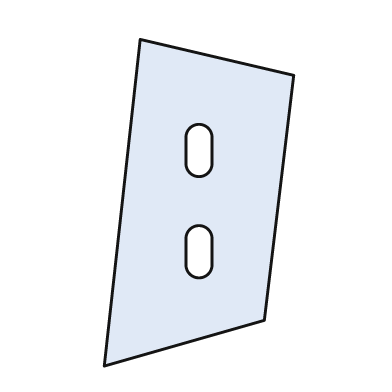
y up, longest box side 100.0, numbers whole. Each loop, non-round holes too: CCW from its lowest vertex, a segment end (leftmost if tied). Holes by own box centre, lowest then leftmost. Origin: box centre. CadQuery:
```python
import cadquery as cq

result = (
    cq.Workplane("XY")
    .moveTo(-29.0, -50.0)
    .lineTo(20.0, -36.0)
    .lineTo(29.0, 39.0)
    .lineTo(-18.0, 50.0)
    .close()
    .moveTo(-4.0, -19.0)
    .threePointArc((0.0, -23.0), (4.0, -19.0))
    .lineTo(4.0, -11.0)
    .threePointArc((0.0, -7.0), (-4.0, -11.0))
    .close()
    .moveTo(-4.0, 12.0)
    .threePointArc((0.0, 8.0), (4.0, 12.0))
    .lineTo(4.0, 20.0)
    .threePointArc((0.0, 24.0), (-4.0, 20.0))
    .close()
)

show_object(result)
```